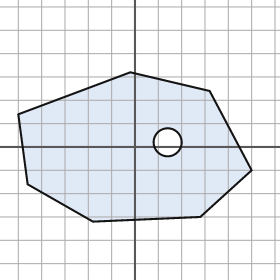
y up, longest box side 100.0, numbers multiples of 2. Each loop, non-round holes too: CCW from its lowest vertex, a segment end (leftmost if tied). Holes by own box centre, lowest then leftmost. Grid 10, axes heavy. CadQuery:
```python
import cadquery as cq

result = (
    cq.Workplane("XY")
    .moveTo(-18.0, -32.0)
    .lineTo(28.0, -30.0)
    .lineTo(50.0, -10.0)
    .lineTo(32.0, 24.0)
    .lineTo(-2.0, 32.0)
    .lineTo(-50.0, 14.0)
    .lineTo(-46.0, -16.0)
    .close()
    .moveTo(14.0, 2.0)
    .circle(6.0)
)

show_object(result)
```